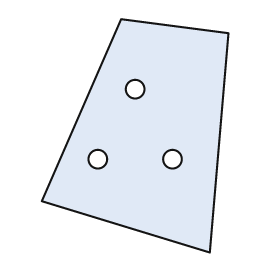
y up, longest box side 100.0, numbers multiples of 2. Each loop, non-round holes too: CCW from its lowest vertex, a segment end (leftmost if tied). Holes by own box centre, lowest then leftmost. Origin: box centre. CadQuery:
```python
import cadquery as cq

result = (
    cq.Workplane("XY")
    .moveTo(32.0, -50.0)
    .lineTo(40.0, 44.0)
    .lineTo(-6.0, 50.0)
    .lineTo(-40.0, -28.0)
    .close()
    .moveTo(-16.0, -10.0)
    .circle(4.0)
    .moveTo(16.0, -10.0)
    .circle(4.0)
    .moveTo(0.0, 20.0)
    .circle(4.0)
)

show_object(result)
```